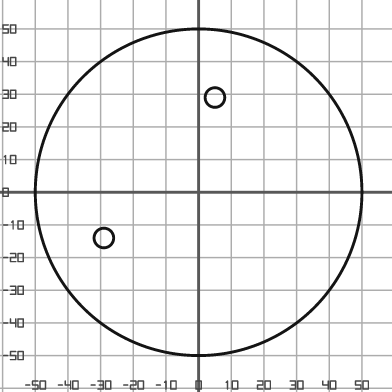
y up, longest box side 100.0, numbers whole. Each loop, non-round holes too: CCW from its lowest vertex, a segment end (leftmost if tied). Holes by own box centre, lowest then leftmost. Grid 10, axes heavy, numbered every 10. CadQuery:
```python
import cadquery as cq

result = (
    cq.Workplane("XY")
    .moveTo(0.0, 0.0)
    .circle(50.0)
    .moveTo(-29.0, -14.0)
    .circle(3.0)
    .moveTo(5.0, 29.0)
    .circle(3.0)
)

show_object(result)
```